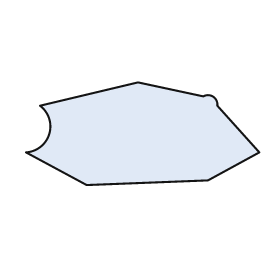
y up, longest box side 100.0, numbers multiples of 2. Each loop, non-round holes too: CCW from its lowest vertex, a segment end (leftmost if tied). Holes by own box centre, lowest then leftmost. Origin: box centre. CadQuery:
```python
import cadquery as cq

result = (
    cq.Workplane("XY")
    .moveTo(-24.0, -22.0)
    .lineTo(28.0, -20.0)
    .lineTo(50.0, -8.0)
    .lineTo(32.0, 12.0)
    .threePointArc((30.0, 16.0), (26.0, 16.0))
    .lineTo(-2.0, 22.0)
    .lineTo(-44.0, 12.0)
    .threePointArc((-40.0, 0.0), (-50.0, -8.0))
    .close()
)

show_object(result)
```